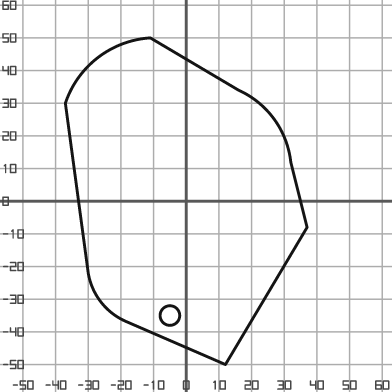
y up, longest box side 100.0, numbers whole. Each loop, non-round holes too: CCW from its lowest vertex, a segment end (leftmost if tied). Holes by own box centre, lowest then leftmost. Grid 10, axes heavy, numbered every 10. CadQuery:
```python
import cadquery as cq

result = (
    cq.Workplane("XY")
    .moveTo(12.0, -50.0)
    .lineTo(37.0, -8.0)
    .lineTo(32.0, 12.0)
    .threePointArc((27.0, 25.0), (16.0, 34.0))
    .lineTo(-11.0, 50.0)
    .threePointArc((-27.0, 44.0), (-37.0, 30.0))
    .lineTo(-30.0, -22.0)
    .threePointArc((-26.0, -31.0), (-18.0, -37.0))
    .close()
    .moveTo(-5.0, -35.0)
    .circle(3.0)
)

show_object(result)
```